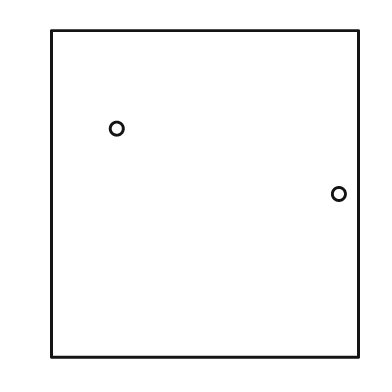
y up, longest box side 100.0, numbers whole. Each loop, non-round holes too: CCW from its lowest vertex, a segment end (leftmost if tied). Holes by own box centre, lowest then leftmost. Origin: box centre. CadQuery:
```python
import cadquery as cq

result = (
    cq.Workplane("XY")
    .moveTo(-47.0, -50.0)
    .lineTo(47.0, -50.0)
    .lineTo(47.0, 50.0)
    .lineTo(-47.0, 50.0)
    .close()
    .moveTo(41.0, 0.0)
    .circle(2.0)
    .moveTo(-27.0, 20.0)
    .circle(2.0)
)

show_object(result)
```